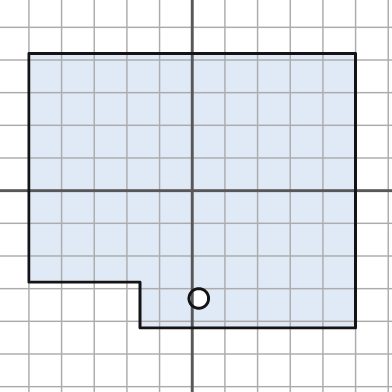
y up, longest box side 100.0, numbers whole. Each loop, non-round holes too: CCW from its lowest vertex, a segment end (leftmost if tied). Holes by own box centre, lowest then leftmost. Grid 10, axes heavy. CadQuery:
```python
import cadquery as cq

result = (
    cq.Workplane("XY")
    .moveTo(-16.0, -42.0)
    .lineTo(50.0, -42.0)
    .lineTo(50.0, 42.0)
    .lineTo(-50.0, 42.0)
    .lineTo(-50.0, -28.0)
    .lineTo(-16.0, -28.0)
    .close()
    .moveTo(2.0, -33.0)
    .circle(3.0)
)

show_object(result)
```